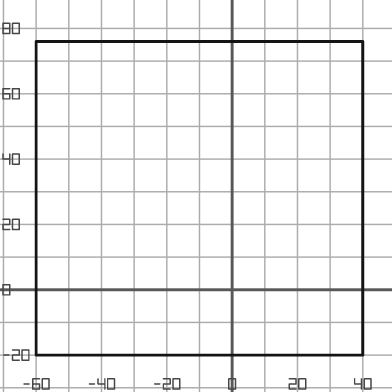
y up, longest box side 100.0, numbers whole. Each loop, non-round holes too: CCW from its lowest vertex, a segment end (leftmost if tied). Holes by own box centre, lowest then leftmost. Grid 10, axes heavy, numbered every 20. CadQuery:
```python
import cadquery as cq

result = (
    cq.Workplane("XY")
    .moveTo(-60.0, -20.0)
    .lineTo(40.0, -20.0)
    .lineTo(40.0, 76.0)
    .lineTo(-60.0, 76.0)
    .close()
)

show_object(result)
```